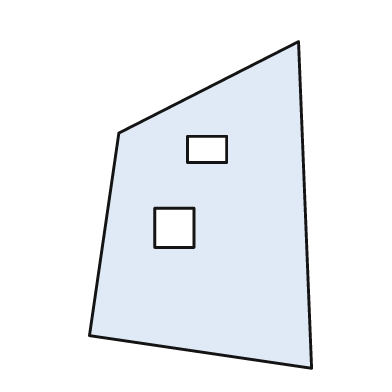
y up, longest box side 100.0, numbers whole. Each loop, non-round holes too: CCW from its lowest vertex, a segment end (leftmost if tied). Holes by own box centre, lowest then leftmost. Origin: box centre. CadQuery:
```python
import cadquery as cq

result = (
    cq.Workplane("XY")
    .moveTo(34.0, -50.0)
    .lineTo(30.0, 50.0)
    .lineTo(-25.0, 22.0)
    .lineTo(-34.0, -40.0)
    .close()
    .moveTo(-14.0, -13.0)
    .lineTo(-2.0, -13.0)
    .lineTo(-2.0, -1.0)
    .lineTo(-14.0, -1.0)
    .close()
    .moveTo(-4.0, 13.0)
    .lineTo(8.0, 13.0)
    .lineTo(8.0, 21.0)
    .lineTo(-4.0, 21.0)
    .close()
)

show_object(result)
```